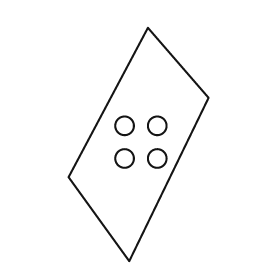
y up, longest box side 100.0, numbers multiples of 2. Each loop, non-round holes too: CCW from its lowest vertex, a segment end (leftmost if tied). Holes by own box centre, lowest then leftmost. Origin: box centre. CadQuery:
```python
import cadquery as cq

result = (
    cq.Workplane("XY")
    .moveTo(-4.0, -50.0)
    .lineTo(30.0, 20.0)
    .lineTo(4.0, 50.0)
    .lineTo(-30.0, -14.0)
    .close()
    .moveTo(-6.0, -6.0)
    .circle(4.0)
    .moveTo(8.0, -6.0)
    .circle(4.0)
    .moveTo(-6.0, 8.0)
    .circle(4.0)
    .moveTo(8.0, 8.0)
    .circle(4.0)
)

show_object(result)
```